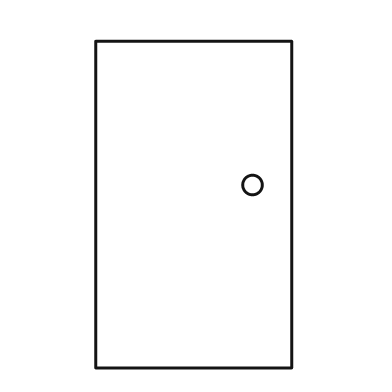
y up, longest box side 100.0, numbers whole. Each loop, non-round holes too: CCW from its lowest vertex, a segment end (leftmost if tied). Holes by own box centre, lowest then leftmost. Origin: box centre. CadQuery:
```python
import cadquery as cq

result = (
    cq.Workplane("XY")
    .moveTo(-30.0, -50.0)
    .lineTo(30.0, -50.0)
    .lineTo(30.0, 50.0)
    .lineTo(-30.0, 50.0)
    .close()
    .moveTo(18.0, 6.0)
    .circle(3.0)
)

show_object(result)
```